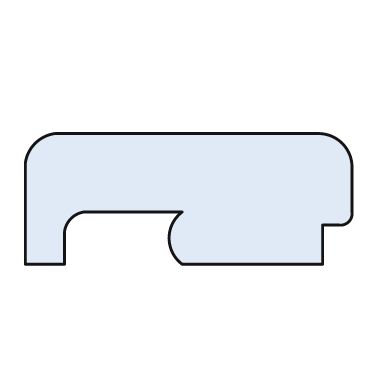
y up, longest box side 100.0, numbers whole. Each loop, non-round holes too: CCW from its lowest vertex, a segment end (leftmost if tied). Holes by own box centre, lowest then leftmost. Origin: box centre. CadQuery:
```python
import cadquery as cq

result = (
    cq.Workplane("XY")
    .moveTo(-50.0, -20.0)
    .lineTo(-38.0, -20.0)
    .lineTo(-38.0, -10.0)
    .threePointArc((-36.0, -6.0), (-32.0, -4.0))
    .lineTo(-2.0, -4.0)
    .threePointArc((-6.0, -12.0), (-2.0, -20.0))
    .lineTo(41.0, -20.0)
    .lineTo(41.0, -8.0)
    .lineTo(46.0, -8.0)
    .threePointArc((49.0, -7.0), (50.0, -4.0))
    .lineTo(50.0, 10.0)
    .threePointArc((47.0, 17.0), (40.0, 20.0))
    .lineTo(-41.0, 20.0)
    .threePointArc((-47.0, 17.0), (-50.0, 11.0))
    .close()
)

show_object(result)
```